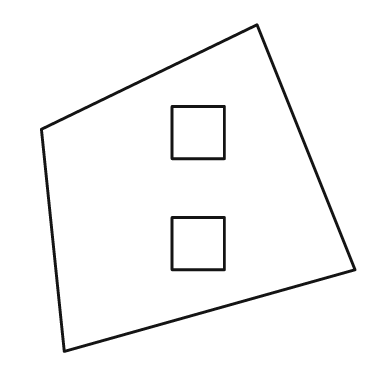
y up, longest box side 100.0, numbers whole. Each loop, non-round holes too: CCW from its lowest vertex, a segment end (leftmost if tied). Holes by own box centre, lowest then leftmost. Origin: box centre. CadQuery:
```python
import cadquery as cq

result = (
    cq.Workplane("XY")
    .moveTo(-41.0, -50.0)
    .lineTo(48.0, -25.0)
    .lineTo(18.0, 50.0)
    .lineTo(-48.0, 18.0)
    .close()
    .moveTo(-8.0, -25.0)
    .lineTo(8.0, -25.0)
    .lineTo(8.0, -9.0)
    .lineTo(-8.0, -9.0)
    .close()
    .moveTo(-8.0, 9.0)
    .lineTo(8.0, 9.0)
    .lineTo(8.0, 25.0)
    .lineTo(-8.0, 25.0)
    .close()
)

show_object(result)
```